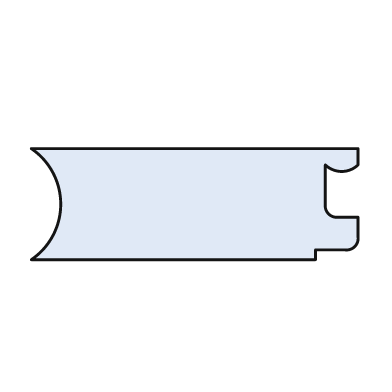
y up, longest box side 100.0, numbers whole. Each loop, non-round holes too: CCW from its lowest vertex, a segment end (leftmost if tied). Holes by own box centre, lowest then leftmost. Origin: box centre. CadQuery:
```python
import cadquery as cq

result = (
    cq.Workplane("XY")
    .moveTo(-50.0, -17.0)
    .lineTo(37.0, -17.0)
    .lineTo(37.0, -14.0)
    .lineTo(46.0, -14.0)
    .threePointArc((49.0, -13.0), (50.0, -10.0))
    .lineTo(50.0, -4.0)
    .lineTo(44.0, -4.0)
    .threePointArc((41.0, -3.0), (40.0, 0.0))
    .lineTo(40.0, 12.0)
    .threePointArc((45.0, 10.0), (50.0, 12.0))
    .lineTo(50.0, 17.0)
    .lineTo(-50.0, 17.0)
    .threePointArc((-41.0, 0.0), (-50.0, -17.0))
    .close()
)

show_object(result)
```